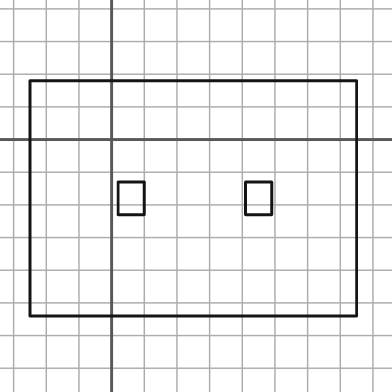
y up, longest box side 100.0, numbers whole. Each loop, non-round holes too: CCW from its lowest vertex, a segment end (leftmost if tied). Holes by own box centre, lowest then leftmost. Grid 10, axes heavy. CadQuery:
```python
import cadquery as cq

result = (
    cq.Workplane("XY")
    .moveTo(-25.0, -54.0)
    .lineTo(75.0, -54.0)
    .lineTo(75.0, 18.0)
    .lineTo(-25.0, 18.0)
    .close()
    .moveTo(2.0, -23.0)
    .lineTo(10.0, -23.0)
    .lineTo(10.0, -13.0)
    .lineTo(2.0, -13.0)
    .close()
    .moveTo(41.0, -23.0)
    .lineTo(49.0, -23.0)
    .lineTo(49.0, -13.0)
    .lineTo(41.0, -13.0)
    .close()
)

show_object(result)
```